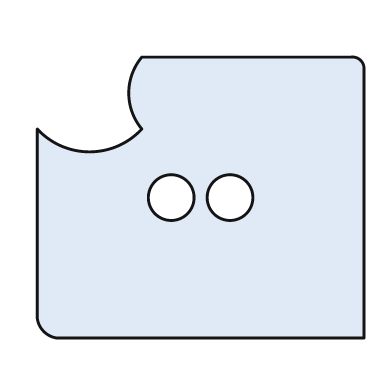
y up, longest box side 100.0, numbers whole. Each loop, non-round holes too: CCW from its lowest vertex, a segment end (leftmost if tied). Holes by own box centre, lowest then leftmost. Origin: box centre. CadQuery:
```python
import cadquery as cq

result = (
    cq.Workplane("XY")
    .moveTo(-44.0, -43.0)
    .lineTo(50.0, -43.0)
    .lineTo(50.0, 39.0)
    .threePointArc((49.0, 42.0), (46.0, 43.0))
    .lineTo(-18.0, 43.0)
    .threePointArc((-22.0, 32.0), (-18.0, 21.0))
    .threePointArc((-34.0, 14.0), (-50.0, 21.0))
    .lineTo(-50.0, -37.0)
    .threePointArc((-48.0, -41.0), (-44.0, -43.0))
    .close()
    .moveTo(-9.0, 0.0)
    .circle(7.0)
    .moveTo(9.0, 0.0)
    .circle(7.0)
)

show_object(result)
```